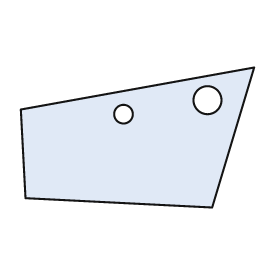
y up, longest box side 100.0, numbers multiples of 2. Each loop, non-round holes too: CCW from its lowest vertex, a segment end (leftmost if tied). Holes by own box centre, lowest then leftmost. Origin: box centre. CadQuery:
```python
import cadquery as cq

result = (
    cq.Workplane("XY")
    .moveTo(32.0, -30.0)
    .lineTo(50.0, 30.0)
    .lineTo(-50.0, 12.0)
    .lineTo(-48.0, -26.0)
    .close()
    .moveTo(-6.0, 10.0)
    .circle(4.0)
    .moveTo(30.0, 16.0)
    .circle(6.0)
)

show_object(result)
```